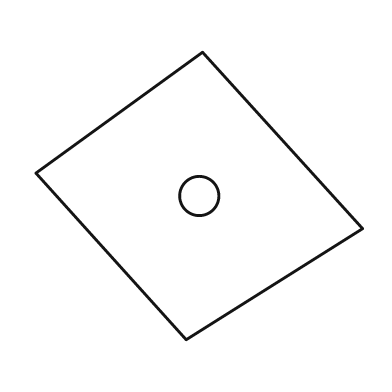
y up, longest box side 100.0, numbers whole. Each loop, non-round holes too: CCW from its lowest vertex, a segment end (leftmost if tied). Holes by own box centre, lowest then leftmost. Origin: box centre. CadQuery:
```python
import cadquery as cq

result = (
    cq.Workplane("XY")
    .moveTo(-4.0, -44.0)
    .lineTo(50.0, -10.0)
    .lineTo(1.0, 44.0)
    .lineTo(-50.0, 7.0)
    .close()
    .moveTo(0.0, 0.0)
    .circle(6.0)
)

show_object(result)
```